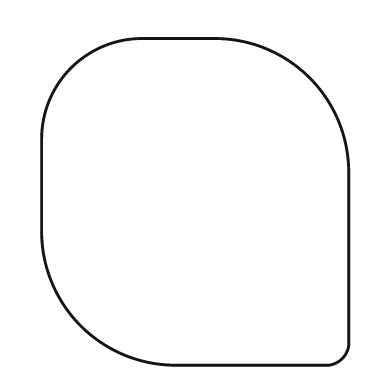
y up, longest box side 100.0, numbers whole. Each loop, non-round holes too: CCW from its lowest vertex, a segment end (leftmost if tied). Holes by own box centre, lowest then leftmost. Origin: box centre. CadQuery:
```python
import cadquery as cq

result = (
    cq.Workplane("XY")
    .moveTo(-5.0, -50.0)
    .lineTo(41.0, -50.0)
    .threePointArc((45.0, -48.0), (47.0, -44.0))
    .lineTo(47.0, 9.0)
    .threePointArc((35.0, 38.0), (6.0, 50.0))
    .lineTo(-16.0, 50.0)
    .threePointArc((-38.0, 41.0), (-47.0, 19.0))
    .lineTo(-47.0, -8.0)
    .threePointArc((-35.0, -38.0), (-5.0, -50.0))
    .close()
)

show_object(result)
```